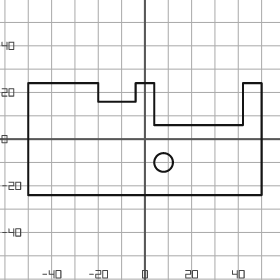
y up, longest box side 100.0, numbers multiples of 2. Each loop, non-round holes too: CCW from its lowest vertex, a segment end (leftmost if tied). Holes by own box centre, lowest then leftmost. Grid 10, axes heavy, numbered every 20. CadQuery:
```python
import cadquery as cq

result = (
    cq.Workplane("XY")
    .moveTo(-50.0, -24.0)
    .lineTo(50.0, -24.0)
    .lineTo(50.0, 24.0)
    .lineTo(42.0, 24.0)
    .lineTo(42.0, 6.0)
    .lineTo(4.0, 6.0)
    .lineTo(4.0, 24.0)
    .lineTo(-4.0, 24.0)
    .lineTo(-4.0, 16.0)
    .lineTo(-20.0, 16.0)
    .lineTo(-20.0, 24.0)
    .lineTo(-50.0, 24.0)
    .close()
    .moveTo(8.0, -10.0)
    .circle(4.0)
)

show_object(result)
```